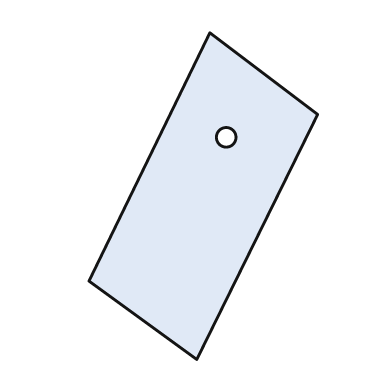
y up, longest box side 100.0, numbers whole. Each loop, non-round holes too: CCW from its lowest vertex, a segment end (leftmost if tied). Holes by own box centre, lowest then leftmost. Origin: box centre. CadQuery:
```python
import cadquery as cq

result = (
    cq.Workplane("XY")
    .moveTo(-2.0, -50.0)
    .lineTo(35.0, 25.0)
    .lineTo(2.0, 50.0)
    .lineTo(-35.0, -26.0)
    .close()
    .moveTo(7.0, 18.0)
    .circle(3.0)
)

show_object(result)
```